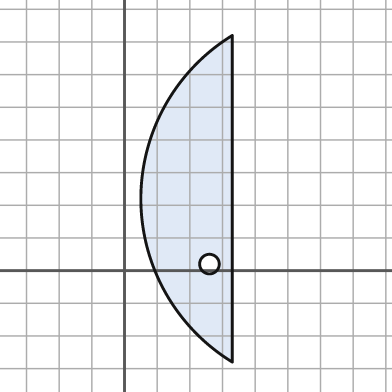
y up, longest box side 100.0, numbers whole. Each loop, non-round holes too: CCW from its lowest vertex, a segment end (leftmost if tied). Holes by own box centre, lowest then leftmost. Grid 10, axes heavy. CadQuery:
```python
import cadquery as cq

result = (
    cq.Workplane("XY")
    .moveTo(33.0, -28.0)
    .lineTo(33.0, 72.0)
    .threePointArc((5.0, 22.0), (33.0, -28.0))
    .close()
    .moveTo(26.0, 2.0)
    .circle(3.0)
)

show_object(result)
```